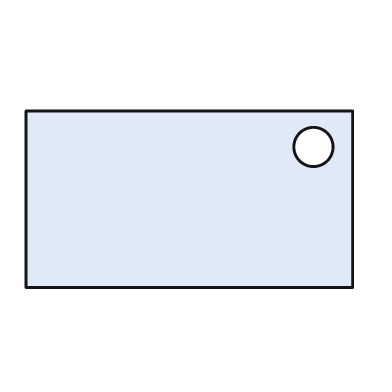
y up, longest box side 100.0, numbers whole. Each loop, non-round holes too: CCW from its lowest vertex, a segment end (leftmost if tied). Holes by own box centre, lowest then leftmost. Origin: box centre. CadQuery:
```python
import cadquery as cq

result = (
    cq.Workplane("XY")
    .moveTo(-50.0, -27.0)
    .lineTo(50.0, -27.0)
    .lineTo(50.0, 27.0)
    .lineTo(-50.0, 27.0)
    .close()
    .moveTo(38.0, 16.0)
    .circle(6.0)
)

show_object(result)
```